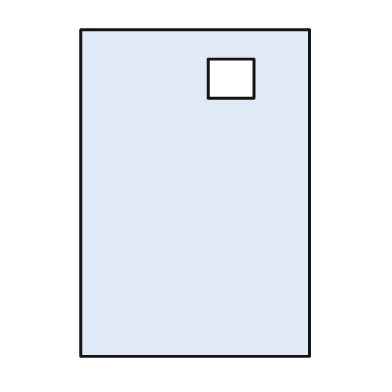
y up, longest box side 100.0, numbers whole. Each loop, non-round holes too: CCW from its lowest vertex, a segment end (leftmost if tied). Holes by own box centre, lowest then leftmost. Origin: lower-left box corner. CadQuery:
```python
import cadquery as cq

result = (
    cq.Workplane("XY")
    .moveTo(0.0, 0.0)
    .lineTo(70.0, 0.0)
    .lineTo(70.0, 100.0)
    .lineTo(0.0, 100.0)
    .close()
    .moveTo(39.0, 79.0)
    .lineTo(53.0, 79.0)
    .lineTo(53.0, 91.0)
    .lineTo(39.0, 91.0)
    .close()
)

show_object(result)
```